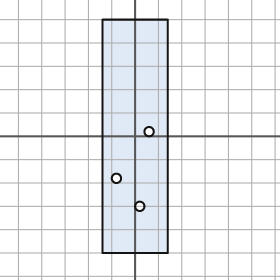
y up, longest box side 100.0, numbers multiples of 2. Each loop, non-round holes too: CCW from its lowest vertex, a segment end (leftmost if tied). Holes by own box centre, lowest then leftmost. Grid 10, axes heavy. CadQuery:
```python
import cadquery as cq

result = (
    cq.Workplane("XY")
    .moveTo(-14.0, -50.0)
    .lineTo(14.0, -50.0)
    .lineTo(14.0, 50.0)
    .lineTo(-14.0, 50.0)
    .close()
    .moveTo(2.0, -30.0)
    .circle(2.0)
    .moveTo(-8.0, -18.0)
    .circle(2.0)
    .moveTo(6.0, 2.0)
    .circle(2.0)
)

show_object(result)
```